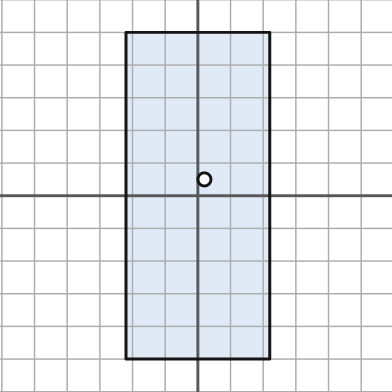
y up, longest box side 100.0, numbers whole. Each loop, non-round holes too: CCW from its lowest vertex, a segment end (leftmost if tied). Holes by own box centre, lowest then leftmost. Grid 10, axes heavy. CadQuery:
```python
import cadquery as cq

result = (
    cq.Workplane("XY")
    .moveTo(-22.0, -50.0)
    .lineTo(22.0, -50.0)
    .lineTo(22.0, 50.0)
    .lineTo(-22.0, 50.0)
    .close()
    .moveTo(2.0, 5.0)
    .circle(2.0)
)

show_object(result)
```